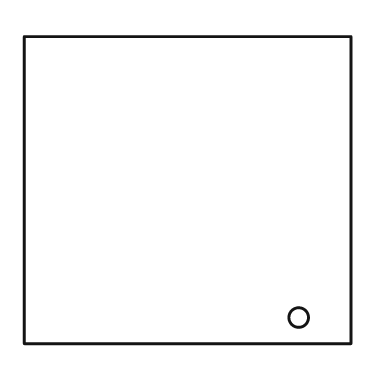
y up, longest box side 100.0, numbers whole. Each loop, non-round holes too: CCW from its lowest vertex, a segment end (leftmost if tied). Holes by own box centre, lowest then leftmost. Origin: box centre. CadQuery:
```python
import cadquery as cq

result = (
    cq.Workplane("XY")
    .moveTo(-50.0, -47.0)
    .lineTo(50.0, -47.0)
    .lineTo(50.0, 47.0)
    .lineTo(-50.0, 47.0)
    .close()
    .moveTo(34.0, -39.0)
    .circle(3.0)
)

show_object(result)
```